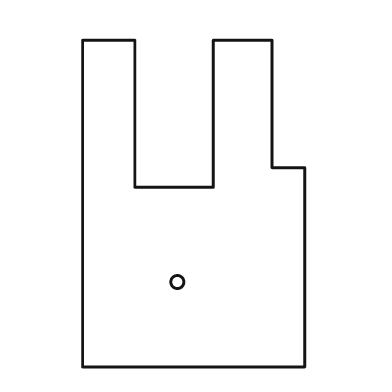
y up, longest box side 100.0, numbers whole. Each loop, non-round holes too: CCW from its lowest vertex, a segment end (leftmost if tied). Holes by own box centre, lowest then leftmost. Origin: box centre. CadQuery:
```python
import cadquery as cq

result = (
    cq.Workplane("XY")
    .moveTo(-34.0, -50.0)
    .lineTo(34.0, -50.0)
    .lineTo(34.0, 11.0)
    .lineTo(24.0, 11.0)
    .lineTo(24.0, 50.0)
    .lineTo(6.0, 50.0)
    .lineTo(6.0, 5.0)
    .lineTo(-18.0, 5.0)
    .lineTo(-18.0, 50.0)
    .lineTo(-34.0, 50.0)
    .close()
    .moveTo(-5.0, -24.0)
    .circle(2.0)
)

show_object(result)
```